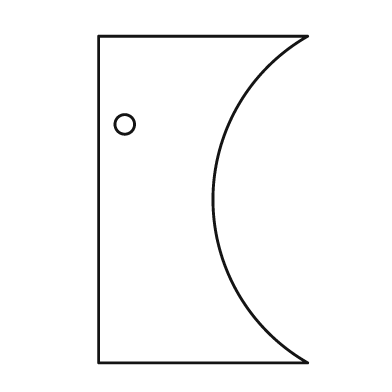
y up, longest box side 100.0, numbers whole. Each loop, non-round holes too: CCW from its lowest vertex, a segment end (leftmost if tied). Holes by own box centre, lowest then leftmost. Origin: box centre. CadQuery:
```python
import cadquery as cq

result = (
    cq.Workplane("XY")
    .moveTo(-32.0, -50.0)
    .lineTo(32.0, -50.0)
    .threePointArc((3.0, 0.0), (32.0, 50.0))
    .lineTo(-32.0, 50.0)
    .close()
    .moveTo(-24.0, 23.0)
    .circle(3.0)
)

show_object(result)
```